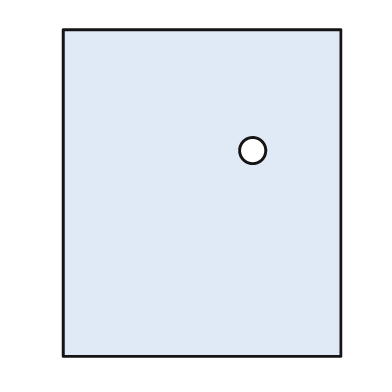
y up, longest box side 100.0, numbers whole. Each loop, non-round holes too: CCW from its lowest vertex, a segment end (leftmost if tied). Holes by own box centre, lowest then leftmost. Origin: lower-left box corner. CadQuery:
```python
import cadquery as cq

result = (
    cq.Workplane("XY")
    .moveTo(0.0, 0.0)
    .lineTo(85.0, 0.0)
    .lineTo(85.0, 100.0)
    .lineTo(0.0, 100.0)
    .close()
    .moveTo(58.0, 63.0)
    .circle(4.0)
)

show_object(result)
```